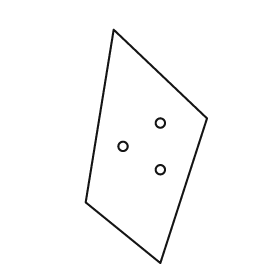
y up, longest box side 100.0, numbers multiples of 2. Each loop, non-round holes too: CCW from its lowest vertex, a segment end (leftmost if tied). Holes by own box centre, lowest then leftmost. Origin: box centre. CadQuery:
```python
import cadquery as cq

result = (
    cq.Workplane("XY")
    .moveTo(6.0, -50.0)
    .lineTo(26.0, 12.0)
    .lineTo(-14.0, 50.0)
    .lineTo(-26.0, -24.0)
    .close()
    .moveTo(6.0, -10.0)
    .circle(2.0)
    .moveTo(-10.0, 0.0)
    .circle(2.0)
    .moveTo(6.0, 10.0)
    .circle(2.0)
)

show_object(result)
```